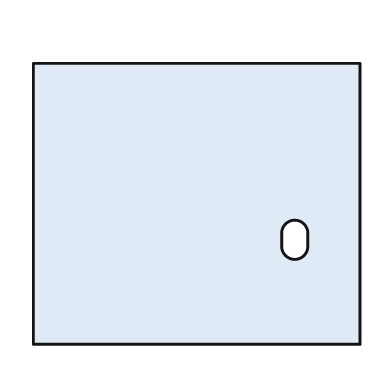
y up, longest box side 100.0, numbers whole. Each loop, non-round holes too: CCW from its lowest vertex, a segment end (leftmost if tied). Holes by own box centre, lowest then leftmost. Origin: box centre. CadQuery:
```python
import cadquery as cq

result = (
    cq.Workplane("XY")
    .moveTo(-50.0, -43.0)
    .lineTo(50.0, -43.0)
    .lineTo(50.0, 43.0)
    .lineTo(-50.0, 43.0)
    .close()
    .moveTo(26.0, -13.0)
    .threePointArc((30.0, -17.0), (34.0, -13.0))
    .lineTo(34.0, -9.0)
    .threePointArc((30.0, -5.0), (26.0, -9.0))
    .close()
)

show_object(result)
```